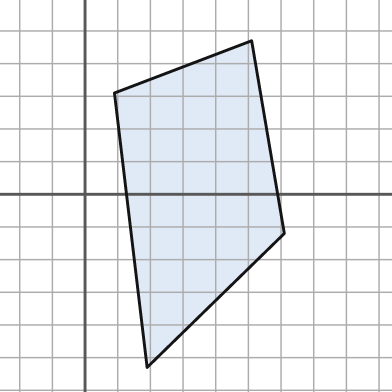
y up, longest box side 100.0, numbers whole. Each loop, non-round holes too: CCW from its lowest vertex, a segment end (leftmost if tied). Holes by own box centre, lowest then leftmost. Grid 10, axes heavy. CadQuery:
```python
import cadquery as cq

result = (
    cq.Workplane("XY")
    .moveTo(19.0, -53.0)
    .lineTo(61.0, -12.0)
    .lineTo(51.0, 47.0)
    .lineTo(9.0, 31.0)
    .close()
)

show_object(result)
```